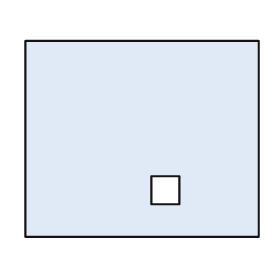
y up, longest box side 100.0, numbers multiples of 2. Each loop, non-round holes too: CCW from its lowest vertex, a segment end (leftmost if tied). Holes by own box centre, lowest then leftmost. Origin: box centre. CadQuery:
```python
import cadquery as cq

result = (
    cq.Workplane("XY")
    .moveTo(-50.0, -42.0)
    .lineTo(50.0, -42.0)
    .lineTo(50.0, 42.0)
    .lineTo(-50.0, 42.0)
    .close()
    .moveTo(4.0, -28.0)
    .lineTo(16.0, -28.0)
    .lineTo(16.0, -16.0)
    .lineTo(4.0, -16.0)
    .close()
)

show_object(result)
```